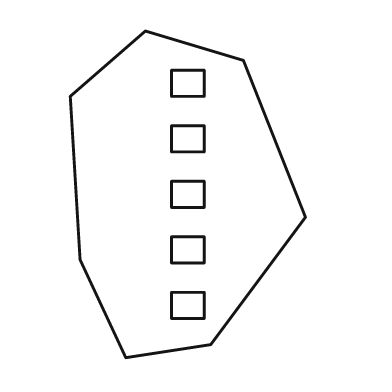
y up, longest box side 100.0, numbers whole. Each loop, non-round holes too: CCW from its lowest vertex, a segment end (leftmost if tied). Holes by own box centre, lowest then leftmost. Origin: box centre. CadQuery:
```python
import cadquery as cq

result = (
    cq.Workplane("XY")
    .moveTo(-19.0, -50.0)
    .lineTo(7.0, -46.0)
    .lineTo(36.0, -7.0)
    .lineTo(17.0, 41.0)
    .lineTo(-13.0, 50.0)
    .lineTo(-36.0, 30.0)
    .lineTo(-33.0, -20.0)
    .close()
    .moveTo(-5.0, -38.0)
    .lineTo(5.0, -38.0)
    .lineTo(5.0, -30.0)
    .lineTo(-5.0, -30.0)
    .close()
    .moveTo(-5.0, -21.0)
    .lineTo(5.0, -21.0)
    .lineTo(5.0, -13.0)
    .lineTo(-5.0, -13.0)
    .close()
    .moveTo(-5.0, -4.0)
    .lineTo(5.0, -4.0)
    .lineTo(5.0, 4.0)
    .lineTo(-5.0, 4.0)
    .close()
    .moveTo(-5.0, 13.0)
    .lineTo(5.0, 13.0)
    .lineTo(5.0, 21.0)
    .lineTo(-5.0, 21.0)
    .close()
    .moveTo(-5.0, 30.0)
    .lineTo(5.0, 30.0)
    .lineTo(5.0, 38.0)
    .lineTo(-5.0, 38.0)
    .close()
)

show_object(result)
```